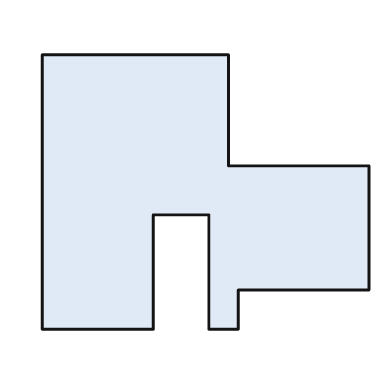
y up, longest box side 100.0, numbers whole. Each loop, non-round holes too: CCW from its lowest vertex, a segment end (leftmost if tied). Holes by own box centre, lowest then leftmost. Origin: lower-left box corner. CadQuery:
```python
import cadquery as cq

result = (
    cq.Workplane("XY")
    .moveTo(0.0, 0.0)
    .lineTo(34.0, 0.0)
    .lineTo(34.0, 35.0)
    .lineTo(51.0, 35.0)
    .lineTo(51.0, 0.0)
    .lineTo(60.0, 0.0)
    .lineTo(60.0, 12.0)
    .lineTo(100.0, 12.0)
    .lineTo(100.0, 50.0)
    .lineTo(57.0, 50.0)
    .lineTo(57.0, 84.0)
    .lineTo(0.0, 84.0)
    .close()
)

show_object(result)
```